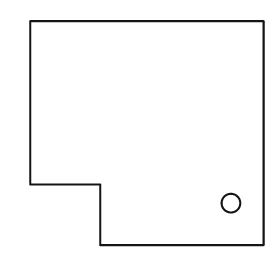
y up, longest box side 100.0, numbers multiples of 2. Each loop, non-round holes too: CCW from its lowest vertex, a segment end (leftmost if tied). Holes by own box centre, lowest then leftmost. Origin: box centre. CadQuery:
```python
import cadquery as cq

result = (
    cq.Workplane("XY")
    .moveTo(-20.0, -48.0)
    .lineTo(50.0, -48.0)
    .lineTo(50.0, 48.0)
    .lineTo(-50.0, 48.0)
    .lineTo(-50.0, -22.0)
    .lineTo(-20.0, -22.0)
    .close()
    .moveTo(36.0, -30.0)
    .circle(4.0)
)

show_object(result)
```